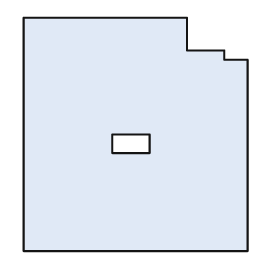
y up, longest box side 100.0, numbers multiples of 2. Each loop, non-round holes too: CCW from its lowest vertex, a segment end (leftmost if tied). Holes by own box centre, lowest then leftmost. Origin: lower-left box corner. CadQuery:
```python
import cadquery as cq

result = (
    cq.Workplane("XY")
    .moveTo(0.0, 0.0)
    .lineTo(96.0, 0.0)
    .lineTo(96.0, 82.0)
    .lineTo(86.0, 82.0)
    .lineTo(86.0, 86.0)
    .lineTo(70.0, 86.0)
    .lineTo(70.0, 100.0)
    .lineTo(0.0, 100.0)
    .close()
    .moveTo(38.0, 42.0)
    .lineTo(54.0, 42.0)
    .lineTo(54.0, 50.0)
    .lineTo(38.0, 50.0)
    .close()
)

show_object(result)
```